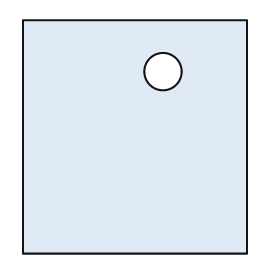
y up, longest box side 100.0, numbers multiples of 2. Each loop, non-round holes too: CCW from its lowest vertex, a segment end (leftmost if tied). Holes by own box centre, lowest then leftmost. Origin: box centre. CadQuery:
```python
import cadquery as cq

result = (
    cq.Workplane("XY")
    .moveTo(-48.0, -50.0)
    .lineTo(48.0, -50.0)
    .lineTo(48.0, 50.0)
    .lineTo(-48.0, 50.0)
    .close()
    .moveTo(12.0, 28.0)
    .circle(8.0)
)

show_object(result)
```